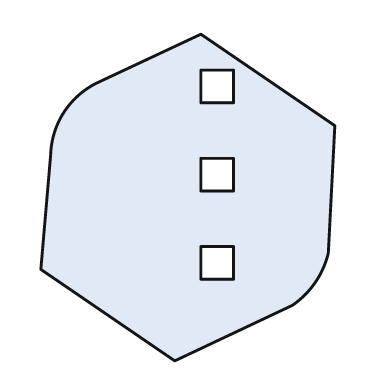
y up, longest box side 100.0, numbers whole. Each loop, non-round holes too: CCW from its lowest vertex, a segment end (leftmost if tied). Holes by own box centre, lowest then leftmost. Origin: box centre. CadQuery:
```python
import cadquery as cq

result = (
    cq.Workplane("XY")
    .moveTo(-4.0, -50.0)
    .lineTo(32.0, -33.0)
    .threePointArc((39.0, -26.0), (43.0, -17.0))
    .lineTo(45.0, 22.0)
    .lineTo(4.0, 50.0)
    .lineTo(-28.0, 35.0)
    .threePointArc((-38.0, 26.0), (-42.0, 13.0))
    .lineTo(-45.0, -22.0)
    .close()
    .moveTo(4.0, -25.0)
    .lineTo(14.0, -25.0)
    .lineTo(14.0, -15.0)
    .lineTo(4.0, -15.0)
    .close()
    .moveTo(4.0, 2.0)
    .lineTo(14.0, 2.0)
    .lineTo(14.0, 12.0)
    .lineTo(4.0, 12.0)
    .close()
    .moveTo(4.0, 29.0)
    .lineTo(14.0, 29.0)
    .lineTo(14.0, 39.0)
    .lineTo(4.0, 39.0)
    .close()
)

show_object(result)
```